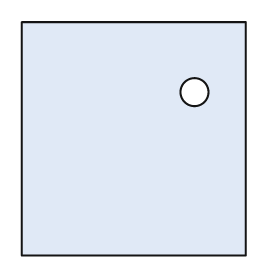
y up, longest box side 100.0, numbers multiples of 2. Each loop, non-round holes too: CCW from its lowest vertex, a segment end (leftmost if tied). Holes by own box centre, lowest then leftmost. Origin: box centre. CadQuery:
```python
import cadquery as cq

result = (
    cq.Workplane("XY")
    .moveTo(-48.0, -50.0)
    .lineTo(48.0, -50.0)
    .lineTo(48.0, 50.0)
    .lineTo(-48.0, 50.0)
    .close()
    .moveTo(26.0, 20.0)
    .circle(6.0)
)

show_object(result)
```